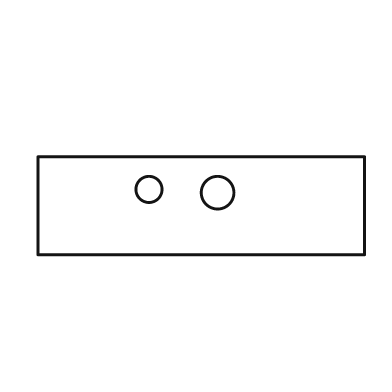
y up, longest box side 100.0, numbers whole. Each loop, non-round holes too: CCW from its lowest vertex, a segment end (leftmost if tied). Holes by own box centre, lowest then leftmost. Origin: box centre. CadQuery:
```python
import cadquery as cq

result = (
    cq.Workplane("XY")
    .moveTo(-50.0, -15.0)
    .lineTo(50.0, -15.0)
    .lineTo(50.0, 15.0)
    .lineTo(-50.0, 15.0)
    .close()
    .moveTo(5.0, 4.0)
    .circle(5.0)
    .moveTo(-16.0, 5.0)
    .circle(4.0)
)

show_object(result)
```